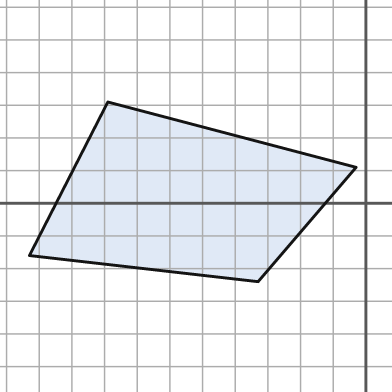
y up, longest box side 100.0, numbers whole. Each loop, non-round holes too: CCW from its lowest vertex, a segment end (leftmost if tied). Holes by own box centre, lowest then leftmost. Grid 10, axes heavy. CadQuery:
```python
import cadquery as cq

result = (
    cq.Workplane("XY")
    .moveTo(-33.0, -24.0)
    .lineTo(-3.0, 11.0)
    .lineTo(-79.0, 31.0)
    .lineTo(-103.0, -16.0)
    .close()
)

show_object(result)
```